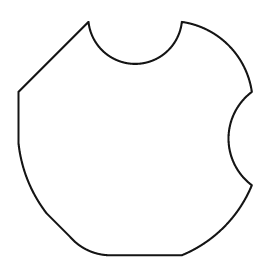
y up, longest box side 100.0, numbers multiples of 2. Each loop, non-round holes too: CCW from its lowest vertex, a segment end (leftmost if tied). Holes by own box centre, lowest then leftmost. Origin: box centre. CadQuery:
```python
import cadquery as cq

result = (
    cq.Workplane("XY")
    .moveTo(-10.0, -50.0)
    .lineTo(20.0, -50.0)
    .threePointArc((38.0, -38.0), (50.0, -20.0))
    .threePointArc((40.0, 0.0), (50.0, 20.0))
    .threePointArc((40.0, 40.0), (20.0, 50.0))
    .threePointArc((0.0, 32.0), (-20.0, 50.0))
    .lineTo(-50.0, 20.0)
    .lineTo(-50.0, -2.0)
    .threePointArc((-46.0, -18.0), (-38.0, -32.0))
    .lineTo(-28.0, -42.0)
    .threePointArc((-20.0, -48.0), (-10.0, -50.0))
    .close()
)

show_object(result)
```